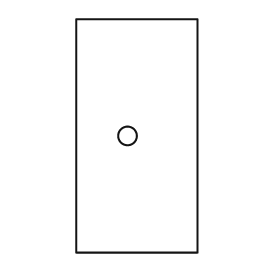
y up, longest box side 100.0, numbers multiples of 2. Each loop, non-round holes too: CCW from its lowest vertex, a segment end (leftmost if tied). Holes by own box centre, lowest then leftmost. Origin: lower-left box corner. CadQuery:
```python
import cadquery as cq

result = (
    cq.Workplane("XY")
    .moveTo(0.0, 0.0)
    .lineTo(52.0, 0.0)
    .lineTo(52.0, 100.0)
    .lineTo(0.0, 100.0)
    .close()
    .moveTo(22.0, 50.0)
    .circle(4.0)
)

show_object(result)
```